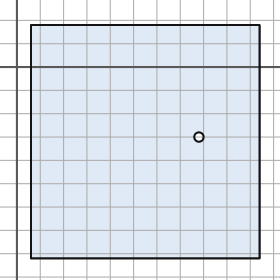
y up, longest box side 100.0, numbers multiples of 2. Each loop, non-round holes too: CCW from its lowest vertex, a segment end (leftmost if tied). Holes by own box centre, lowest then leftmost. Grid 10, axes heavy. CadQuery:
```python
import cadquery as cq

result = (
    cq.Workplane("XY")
    .moveTo(6.0, -82.0)
    .lineTo(104.0, -82.0)
    .lineTo(104.0, 18.0)
    .lineTo(6.0, 18.0)
    .close()
    .moveTo(78.0, -30.0)
    .circle(2.0)
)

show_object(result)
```